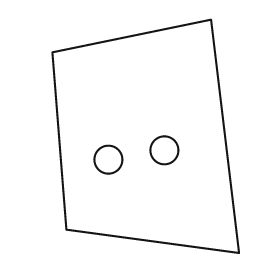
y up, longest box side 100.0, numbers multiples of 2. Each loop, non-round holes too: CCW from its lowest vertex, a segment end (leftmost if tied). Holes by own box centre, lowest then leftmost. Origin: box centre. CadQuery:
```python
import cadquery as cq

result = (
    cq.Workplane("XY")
    .moveTo(40.0, -50.0)
    .lineTo(28.0, 50.0)
    .lineTo(-40.0, 36.0)
    .lineTo(-34.0, -40.0)
    .close()
    .moveTo(-16.0, -10.0)
    .circle(6.0)
    .moveTo(8.0, -6.0)
    .circle(6.0)
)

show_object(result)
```